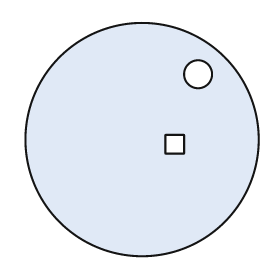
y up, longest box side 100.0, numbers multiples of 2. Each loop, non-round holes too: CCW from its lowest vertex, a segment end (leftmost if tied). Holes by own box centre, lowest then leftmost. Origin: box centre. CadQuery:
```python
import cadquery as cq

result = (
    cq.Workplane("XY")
    .moveTo(0.0, 0.0)
    .circle(50.0)
    .moveTo(10.0, -6.0)
    .lineTo(18.0, -6.0)
    .lineTo(18.0, 2.0)
    .lineTo(10.0, 2.0)
    .close()
    .moveTo(24.0, 28.0)
    .circle(6.0)
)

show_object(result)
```